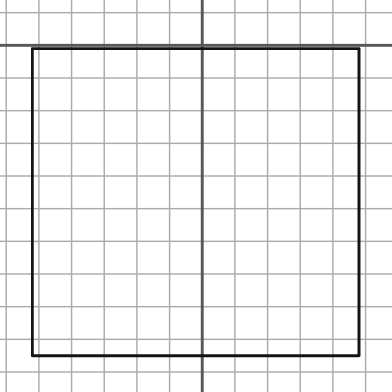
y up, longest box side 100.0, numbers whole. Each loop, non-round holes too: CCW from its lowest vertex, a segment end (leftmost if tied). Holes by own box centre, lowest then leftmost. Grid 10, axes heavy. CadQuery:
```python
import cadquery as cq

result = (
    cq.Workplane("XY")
    .moveTo(-52.0, -95.0)
    .lineTo(48.0, -95.0)
    .lineTo(48.0, -1.0)
    .lineTo(-52.0, -1.0)
    .close()
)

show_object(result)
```